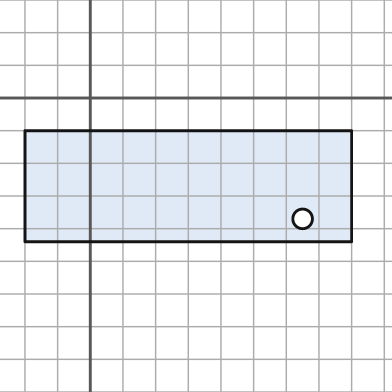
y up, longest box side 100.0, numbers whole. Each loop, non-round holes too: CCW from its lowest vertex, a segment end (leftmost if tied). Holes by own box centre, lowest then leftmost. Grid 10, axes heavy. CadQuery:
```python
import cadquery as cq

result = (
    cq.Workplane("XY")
    .moveTo(-20.0, -44.0)
    .lineTo(80.0, -44.0)
    .lineTo(80.0, -10.0)
    .lineTo(-20.0, -10.0)
    .close()
    .moveTo(65.0, -37.0)
    .circle(3.0)
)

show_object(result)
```